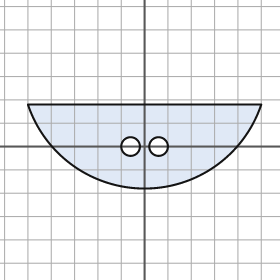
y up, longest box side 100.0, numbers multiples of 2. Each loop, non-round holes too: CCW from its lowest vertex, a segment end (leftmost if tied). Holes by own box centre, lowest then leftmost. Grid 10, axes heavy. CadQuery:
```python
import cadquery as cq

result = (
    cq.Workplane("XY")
    .moveTo(-50.0, 18.0)
    .threePointArc((0.0, -18.0), (50.0, 18.0))
    .close()
    .moveTo(-6.0, 0.0)
    .circle(4.0)
    .moveTo(6.0, 0.0)
    .circle(4.0)
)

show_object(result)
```